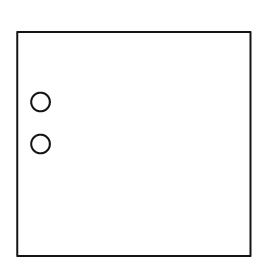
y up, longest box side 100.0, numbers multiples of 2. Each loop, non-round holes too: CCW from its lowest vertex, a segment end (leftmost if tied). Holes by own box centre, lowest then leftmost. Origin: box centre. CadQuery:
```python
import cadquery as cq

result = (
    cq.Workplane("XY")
    .moveTo(-50.0, -48.0)
    .lineTo(50.0, -48.0)
    .lineTo(50.0, 48.0)
    .lineTo(-50.0, 48.0)
    .close()
    .moveTo(-40.0, 0.0)
    .circle(4.0)
    .moveTo(-40.0, 18.0)
    .circle(4.0)
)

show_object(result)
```